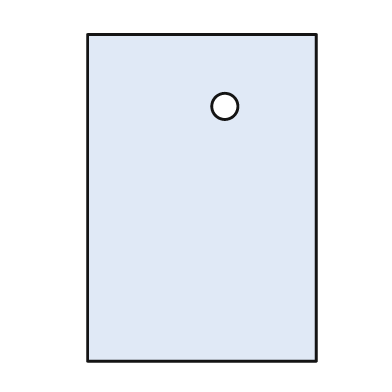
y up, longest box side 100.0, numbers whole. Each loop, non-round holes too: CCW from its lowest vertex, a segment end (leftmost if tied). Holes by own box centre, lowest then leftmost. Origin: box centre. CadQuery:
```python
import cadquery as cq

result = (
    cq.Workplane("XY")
    .moveTo(-35.0, -50.0)
    .lineTo(35.0, -50.0)
    .lineTo(35.0, 50.0)
    .lineTo(-35.0, 50.0)
    .close()
    .moveTo(7.0, 28.0)
    .circle(4.0)
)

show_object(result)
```